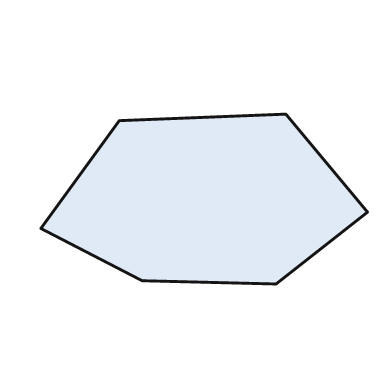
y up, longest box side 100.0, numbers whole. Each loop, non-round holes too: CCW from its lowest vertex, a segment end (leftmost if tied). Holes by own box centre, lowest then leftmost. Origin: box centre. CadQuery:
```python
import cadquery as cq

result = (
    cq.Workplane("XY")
    .moveTo(22.0, -26.0)
    .lineTo(50.0, -4.0)
    .lineTo(25.0, 26.0)
    .lineTo(-26.0, 24.0)
    .lineTo(-50.0, -9.0)
    .lineTo(-19.0, -25.0)
    .close()
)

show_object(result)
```